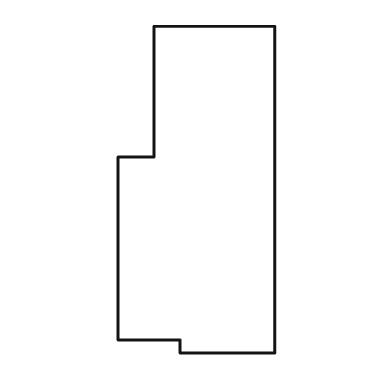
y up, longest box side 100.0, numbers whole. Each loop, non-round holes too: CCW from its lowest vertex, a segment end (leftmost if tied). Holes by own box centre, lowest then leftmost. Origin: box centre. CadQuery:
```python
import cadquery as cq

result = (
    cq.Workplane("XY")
    .moveTo(-5.0, -50.0)
    .lineTo(24.0, -50.0)
    .lineTo(24.0, 50.0)
    .lineTo(-13.0, 50.0)
    .lineTo(-13.0, 10.0)
    .lineTo(-24.0, 10.0)
    .lineTo(-24.0, -46.0)
    .lineTo(-5.0, -46.0)
    .close()
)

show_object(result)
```